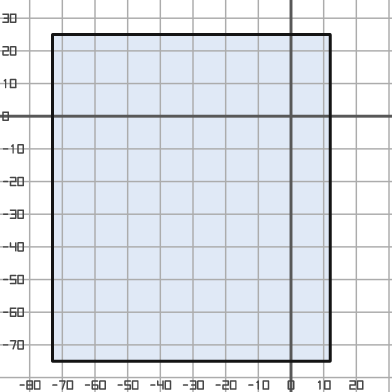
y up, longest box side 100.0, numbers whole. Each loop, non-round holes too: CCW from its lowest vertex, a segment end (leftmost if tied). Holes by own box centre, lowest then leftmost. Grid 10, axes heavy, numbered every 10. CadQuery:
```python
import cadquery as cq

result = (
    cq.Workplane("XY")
    .moveTo(-73.0, -75.0)
    .lineTo(12.0, -75.0)
    .lineTo(12.0, 25.0)
    .lineTo(-73.0, 25.0)
    .close()
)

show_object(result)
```